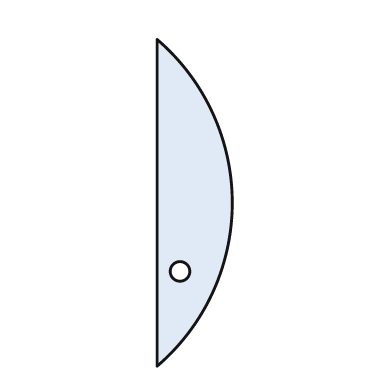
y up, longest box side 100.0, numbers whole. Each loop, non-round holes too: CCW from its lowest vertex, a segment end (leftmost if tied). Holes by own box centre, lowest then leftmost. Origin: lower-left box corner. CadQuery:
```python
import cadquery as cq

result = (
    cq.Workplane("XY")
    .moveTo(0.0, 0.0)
    .threePointArc((23.0, 50.0), (0.0, 100.0))
    .close()
    .moveTo(7.0, 29.0)
    .circle(3.0)
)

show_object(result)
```